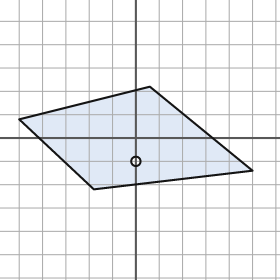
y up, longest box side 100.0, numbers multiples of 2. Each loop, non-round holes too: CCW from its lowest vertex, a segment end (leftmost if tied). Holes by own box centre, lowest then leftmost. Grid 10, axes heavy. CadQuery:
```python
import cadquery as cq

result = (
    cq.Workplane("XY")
    .moveTo(-18.0, -22.0)
    .lineTo(50.0, -14.0)
    .lineTo(6.0, 22.0)
    .lineTo(-50.0, 8.0)
    .close()
    .moveTo(0.0, -10.0)
    .circle(2.0)
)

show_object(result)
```